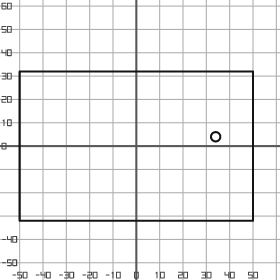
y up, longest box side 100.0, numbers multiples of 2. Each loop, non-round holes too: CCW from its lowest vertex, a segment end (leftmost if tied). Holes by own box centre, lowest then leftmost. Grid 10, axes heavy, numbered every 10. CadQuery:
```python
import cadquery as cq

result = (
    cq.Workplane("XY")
    .moveTo(-50.0, -32.0)
    .lineTo(50.0, -32.0)
    .lineTo(50.0, 32.0)
    .lineTo(-50.0, 32.0)
    .close()
    .moveTo(34.0, 4.0)
    .circle(2.0)
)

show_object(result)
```